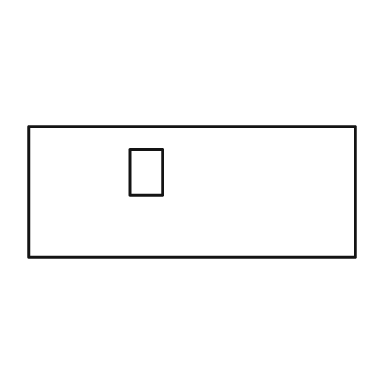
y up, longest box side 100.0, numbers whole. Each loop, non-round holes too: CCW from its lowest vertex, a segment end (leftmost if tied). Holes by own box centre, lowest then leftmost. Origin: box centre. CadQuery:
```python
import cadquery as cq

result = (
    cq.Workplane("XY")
    .moveTo(-50.0, -20.0)
    .lineTo(50.0, -20.0)
    .lineTo(50.0, 20.0)
    .lineTo(-50.0, 20.0)
    .close()
    .moveTo(-19.0, -1.0)
    .lineTo(-9.0, -1.0)
    .lineTo(-9.0, 13.0)
    .lineTo(-19.0, 13.0)
    .close()
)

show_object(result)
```